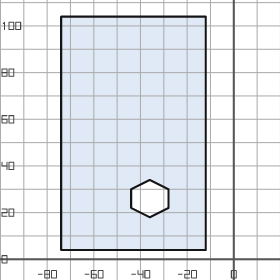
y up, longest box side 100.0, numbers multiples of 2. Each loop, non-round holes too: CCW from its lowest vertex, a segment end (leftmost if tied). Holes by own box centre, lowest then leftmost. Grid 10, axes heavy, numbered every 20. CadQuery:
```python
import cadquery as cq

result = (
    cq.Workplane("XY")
    .moveTo(-74.0, 4.0)
    .lineTo(-12.0, 4.0)
    .lineTo(-12.0, 104.0)
    .lineTo(-74.0, 104.0)
    .close()
    .moveTo(-36.0, 18.0)
    .lineTo(-28.0, 22.0)
    .lineTo(-28.0, 30.0)
    .lineTo(-36.0, 34.0)
    .lineTo(-44.0, 30.0)
    .lineTo(-44.0, 22.0)
    .close()
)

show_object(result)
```